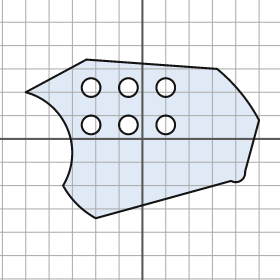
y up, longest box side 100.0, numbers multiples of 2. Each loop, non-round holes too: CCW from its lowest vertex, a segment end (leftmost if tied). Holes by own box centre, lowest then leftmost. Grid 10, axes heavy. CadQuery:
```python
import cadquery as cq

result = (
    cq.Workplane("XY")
    .moveTo(-20.0, -34.0)
    .lineTo(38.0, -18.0)
    .threePointArc((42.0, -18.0), (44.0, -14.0))
    .lineTo(50.0, 8.0)
    .threePointArc((42.0, 20.0), (32.0, 30.0))
    .lineTo(-24.0, 34.0)
    .lineTo(-50.0, 20.0)
    .threePointArc((-32.0, 4.0), (-34.0, -20.0))
    .threePointArc((-28.0, -28.0), (-20.0, -34.0))
    .close()
    .moveTo(-22.0, 6.0)
    .circle(4.0)
    .moveTo(-6.0, 6.0)
    .circle(4.0)
    .moveTo(10.0, 6.0)
    .circle(4.0)
    .moveTo(-22.0, 22.0)
    .circle(4.0)
    .moveTo(-6.0, 22.0)
    .circle(4.0)
    .moveTo(10.0, 22.0)
    .circle(4.0)
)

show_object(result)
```